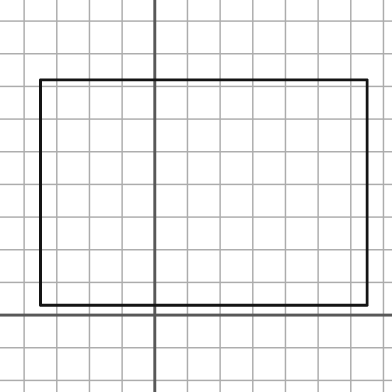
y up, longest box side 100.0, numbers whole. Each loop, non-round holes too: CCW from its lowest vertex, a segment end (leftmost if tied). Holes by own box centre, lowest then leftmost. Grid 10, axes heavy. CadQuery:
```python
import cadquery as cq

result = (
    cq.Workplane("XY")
    .moveTo(-35.0, 3.0)
    .lineTo(65.0, 3.0)
    .lineTo(65.0, 72.0)
    .lineTo(-35.0, 72.0)
    .close()
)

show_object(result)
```